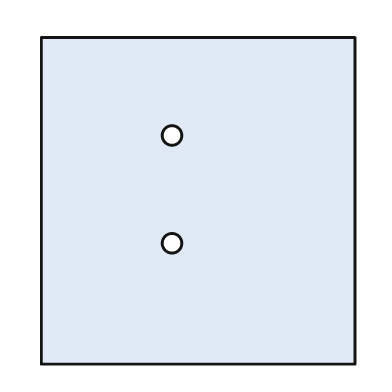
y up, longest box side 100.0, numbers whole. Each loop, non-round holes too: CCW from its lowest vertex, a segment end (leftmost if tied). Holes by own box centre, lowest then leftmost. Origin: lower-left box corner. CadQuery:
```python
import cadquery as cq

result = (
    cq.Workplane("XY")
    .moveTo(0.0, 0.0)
    .lineTo(96.0, 0.0)
    .lineTo(96.0, 100.0)
    .lineTo(0.0, 100.0)
    .close()
    .moveTo(40.0, 37.0)
    .circle(3.0)
    .moveTo(40.0, 70.0)
    .circle(3.0)
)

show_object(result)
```